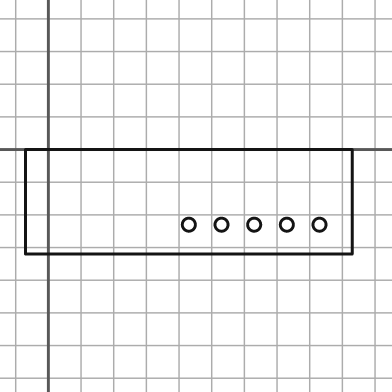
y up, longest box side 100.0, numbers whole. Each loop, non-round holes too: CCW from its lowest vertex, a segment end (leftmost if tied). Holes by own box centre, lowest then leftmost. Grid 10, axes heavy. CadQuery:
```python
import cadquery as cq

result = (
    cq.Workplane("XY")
    .moveTo(-7.0, -32.0)
    .lineTo(93.0, -32.0)
    .lineTo(93.0, 0.0)
    .lineTo(-7.0, 0.0)
    .close()
    .moveTo(43.0, -23.0)
    .circle(2.0)
    .moveTo(53.0, -23.0)
    .circle(2.0)
    .moveTo(63.0, -23.0)
    .circle(2.0)
    .moveTo(73.0, -23.0)
    .circle(2.0)
    .moveTo(83.0, -23.0)
    .circle(2.0)
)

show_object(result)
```